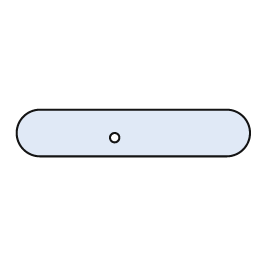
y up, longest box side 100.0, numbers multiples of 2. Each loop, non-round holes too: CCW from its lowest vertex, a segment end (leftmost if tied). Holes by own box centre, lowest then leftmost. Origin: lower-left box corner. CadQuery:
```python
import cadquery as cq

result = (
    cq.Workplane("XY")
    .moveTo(10.0, 0.0)
    .lineTo(90.0, 0.0)
    .threePointArc((100.0, 10.0), (90.0, 20.0))
    .lineTo(10.0, 20.0)
    .threePointArc((0.0, 10.0), (10.0, 0.0))
    .close()
    .moveTo(42.0, 8.0)
    .circle(2.0)
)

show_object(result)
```